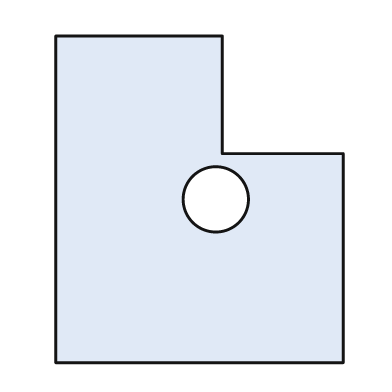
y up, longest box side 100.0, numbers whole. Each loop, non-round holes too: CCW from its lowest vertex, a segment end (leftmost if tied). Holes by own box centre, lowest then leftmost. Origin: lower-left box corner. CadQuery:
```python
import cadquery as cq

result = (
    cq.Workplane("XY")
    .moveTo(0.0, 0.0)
    .lineTo(88.0, 0.0)
    .lineTo(88.0, 64.0)
    .lineTo(51.0, 64.0)
    .lineTo(51.0, 100.0)
    .lineTo(0.0, 100.0)
    .close()
    .moveTo(49.0, 50.0)
    .circle(10.0)
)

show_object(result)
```